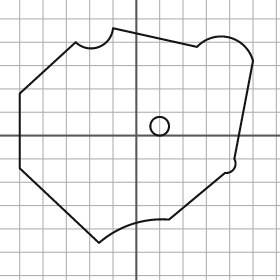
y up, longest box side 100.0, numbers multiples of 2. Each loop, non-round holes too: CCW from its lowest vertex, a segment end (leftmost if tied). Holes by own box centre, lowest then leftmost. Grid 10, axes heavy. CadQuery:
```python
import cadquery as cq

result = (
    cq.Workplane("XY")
    .moveTo(-16.0, -46.0)
    .threePointArc((-2.0, -38.0), (14.0, -36.0))
    .lineTo(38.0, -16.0)
    .threePointArc((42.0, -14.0), (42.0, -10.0))
    .lineTo(50.0, 32.0)
    .threePointArc((40.0, 42.0), (26.0, 38.0))
    .lineTo(-10.0, 46.0)
    .threePointArc((-16.0, 38.0), (-26.0, 40.0))
    .lineTo(-50.0, 18.0)
    .lineTo(-50.0, -14.0)
    .close()
    .moveTo(10.0, 4.0)
    .circle(4.0)
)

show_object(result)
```